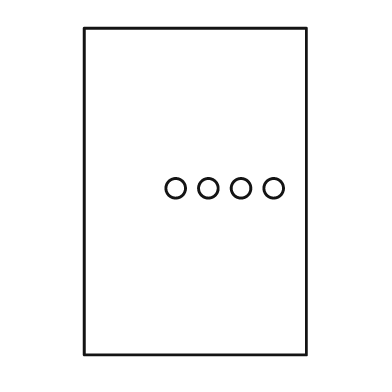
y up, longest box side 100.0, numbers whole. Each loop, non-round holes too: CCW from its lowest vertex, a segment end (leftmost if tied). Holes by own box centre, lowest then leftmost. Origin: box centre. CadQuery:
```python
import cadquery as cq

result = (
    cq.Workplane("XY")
    .moveTo(-34.0, -50.0)
    .lineTo(34.0, -50.0)
    .lineTo(34.0, 50.0)
    .lineTo(-34.0, 50.0)
    .close()
    .moveTo(-6.0, 1.0)
    .circle(3.0)
    .moveTo(4.0, 1.0)
    .circle(3.0)
    .moveTo(14.0, 1.0)
    .circle(3.0)
    .moveTo(24.0, 1.0)
    .circle(3.0)
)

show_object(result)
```